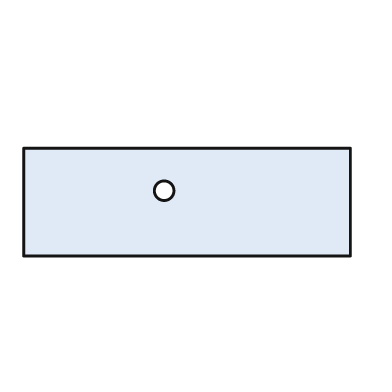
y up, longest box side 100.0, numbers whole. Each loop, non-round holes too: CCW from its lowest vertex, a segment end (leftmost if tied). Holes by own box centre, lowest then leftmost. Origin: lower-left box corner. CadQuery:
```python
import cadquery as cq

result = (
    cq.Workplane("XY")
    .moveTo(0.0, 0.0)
    .lineTo(100.0, 0.0)
    .lineTo(100.0, 33.0)
    .lineTo(0.0, 33.0)
    .close()
    .moveTo(43.0, 20.0)
    .circle(3.0)
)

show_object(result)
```